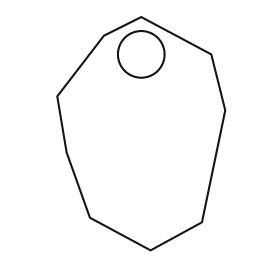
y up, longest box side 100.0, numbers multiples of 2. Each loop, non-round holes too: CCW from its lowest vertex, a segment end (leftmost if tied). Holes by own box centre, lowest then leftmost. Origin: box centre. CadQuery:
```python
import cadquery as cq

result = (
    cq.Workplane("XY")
    .moveTo(4.0, -50.0)
    .lineTo(26.0, -38.0)
    .lineTo(36.0, 10.0)
    .lineTo(30.0, 34.0)
    .lineTo(0.0, 50.0)
    .lineTo(-16.0, 42.0)
    .lineTo(-36.0, 16.0)
    .lineTo(-32.0, -8.0)
    .lineTo(-22.0, -36.0)
    .close()
    .moveTo(0.0, 34.0)
    .circle(10.0)
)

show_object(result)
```